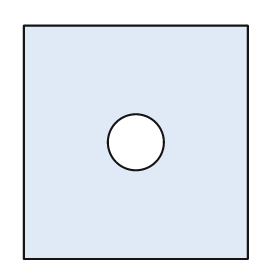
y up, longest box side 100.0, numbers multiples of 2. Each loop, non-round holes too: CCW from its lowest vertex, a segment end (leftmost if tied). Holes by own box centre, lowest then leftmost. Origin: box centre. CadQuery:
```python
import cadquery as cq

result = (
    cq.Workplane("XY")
    .moveTo(-48.0, -50.0)
    .lineTo(48.0, -50.0)
    .lineTo(48.0, 50.0)
    .lineTo(-48.0, 50.0)
    .close()
    .moveTo(0.0, 0.0)
    .circle(12.0)
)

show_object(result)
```